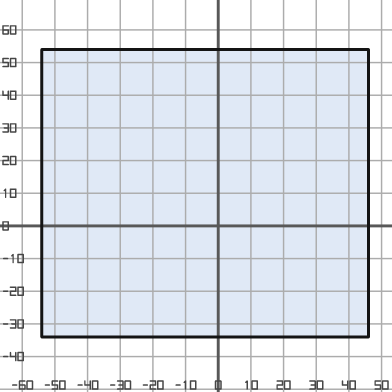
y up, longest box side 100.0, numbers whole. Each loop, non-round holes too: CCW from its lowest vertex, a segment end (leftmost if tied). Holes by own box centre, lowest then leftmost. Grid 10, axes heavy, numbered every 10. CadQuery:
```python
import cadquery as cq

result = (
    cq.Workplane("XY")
    .moveTo(-54.0, -34.0)
    .lineTo(46.0, -34.0)
    .lineTo(46.0, 54.0)
    .lineTo(-54.0, 54.0)
    .close()
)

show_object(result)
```